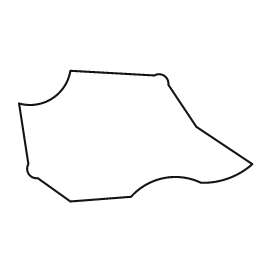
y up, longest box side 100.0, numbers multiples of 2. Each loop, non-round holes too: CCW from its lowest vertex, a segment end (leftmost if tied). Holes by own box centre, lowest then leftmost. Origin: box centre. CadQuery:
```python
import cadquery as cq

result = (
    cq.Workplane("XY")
    .moveTo(-28.0, -28.0)
    .lineTo(-2.0, -26.0)
    .threePointArc((12.0, -18.0), (28.0, -20.0))
    .threePointArc((40.0, -18.0), (50.0, -12.0))
    .lineTo(26.0, 4.0)
    .lineTo(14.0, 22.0)
    .threePointArc((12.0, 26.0), (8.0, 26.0))
    .lineTo(-28.0, 28.0)
    .threePointArc((-36.0, 16.0), (-50.0, 14.0))
    .lineTo(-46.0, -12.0)
    .threePointArc((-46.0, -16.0), (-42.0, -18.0))
    .close()
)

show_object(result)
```